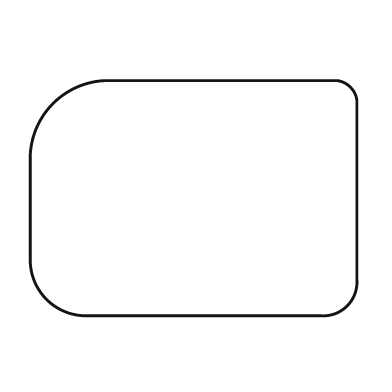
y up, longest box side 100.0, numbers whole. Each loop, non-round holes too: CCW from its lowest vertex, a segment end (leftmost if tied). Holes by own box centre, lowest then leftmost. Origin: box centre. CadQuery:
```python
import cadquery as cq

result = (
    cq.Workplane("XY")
    .moveTo(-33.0, -36.0)
    .lineTo(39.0, -36.0)
    .threePointArc((47.0, -33.0), (50.0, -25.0))
    .lineTo(50.0, 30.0)
    .threePointArc((48.0, 34.0), (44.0, 36.0))
    .lineTo(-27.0, 36.0)
    .threePointArc((-43.0, 29.0), (-50.0, 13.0))
    .lineTo(-50.0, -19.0)
    .threePointArc((-45.0, -31.0), (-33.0, -36.0))
    .close()
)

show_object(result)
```